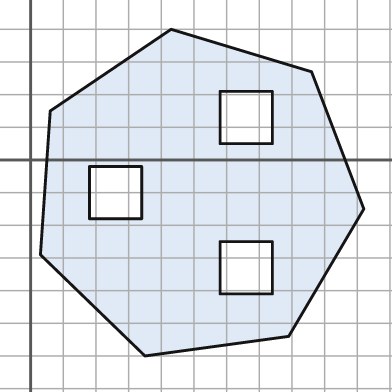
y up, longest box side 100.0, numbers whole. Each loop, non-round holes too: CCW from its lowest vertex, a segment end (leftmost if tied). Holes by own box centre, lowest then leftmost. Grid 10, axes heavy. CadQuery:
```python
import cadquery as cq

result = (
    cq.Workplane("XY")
    .moveTo(35.0, -60.0)
    .lineTo(79.0, -54.0)
    .lineTo(102.0, -15.0)
    .lineTo(86.0, 27.0)
    .lineTo(43.0, 40.0)
    .lineTo(6.0, 15.0)
    .lineTo(3.0, -29.0)
    .close()
    .moveTo(58.0, -41.0)
    .lineTo(74.0, -41.0)
    .lineTo(74.0, -25.0)
    .lineTo(58.0, -25.0)
    .close()
    .moveTo(18.0, -18.0)
    .lineTo(34.0, -18.0)
    .lineTo(34.0, -2.0)
    .lineTo(18.0, -2.0)
    .close()
    .moveTo(58.0, 5.0)
    .lineTo(74.0, 5.0)
    .lineTo(74.0, 21.0)
    .lineTo(58.0, 21.0)
    .close()
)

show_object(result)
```